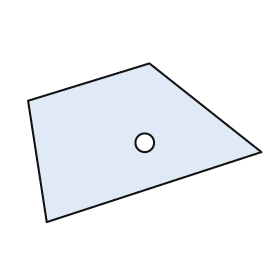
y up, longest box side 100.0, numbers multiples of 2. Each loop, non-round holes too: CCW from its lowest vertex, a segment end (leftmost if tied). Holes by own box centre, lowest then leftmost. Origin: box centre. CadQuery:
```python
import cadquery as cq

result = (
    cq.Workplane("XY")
    .moveTo(-42.0, -34.0)
    .lineTo(50.0, -4.0)
    .lineTo(2.0, 34.0)
    .lineTo(-50.0, 18.0)
    .close()
    .moveTo(0.0, 0.0)
    .circle(4.0)
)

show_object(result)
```